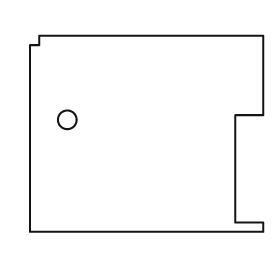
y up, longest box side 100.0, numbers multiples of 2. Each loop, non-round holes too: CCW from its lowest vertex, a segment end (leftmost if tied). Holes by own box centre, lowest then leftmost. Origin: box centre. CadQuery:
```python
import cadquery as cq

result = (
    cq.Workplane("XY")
    .moveTo(-50.0, -42.0)
    .lineTo(50.0, -42.0)
    .lineTo(50.0, -38.0)
    .lineTo(38.0, -38.0)
    .lineTo(38.0, 8.0)
    .lineTo(50.0, 8.0)
    .lineTo(50.0, 42.0)
    .lineTo(-46.0, 42.0)
    .lineTo(-46.0, 38.0)
    .lineTo(-50.0, 38.0)
    .close()
    .moveTo(-34.0, 6.0)
    .circle(4.0)
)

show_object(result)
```